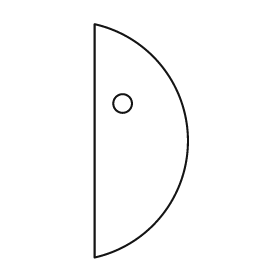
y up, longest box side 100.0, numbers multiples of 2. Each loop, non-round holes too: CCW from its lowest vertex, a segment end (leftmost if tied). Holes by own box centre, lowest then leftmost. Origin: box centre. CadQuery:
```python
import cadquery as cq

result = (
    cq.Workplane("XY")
    .moveTo(-20.0, -50.0)
    .threePointArc((20.0, 0.0), (-20.0, 50.0))
    .close()
    .moveTo(-8.0, 16.0)
    .circle(4.0)
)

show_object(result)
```